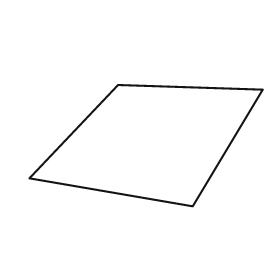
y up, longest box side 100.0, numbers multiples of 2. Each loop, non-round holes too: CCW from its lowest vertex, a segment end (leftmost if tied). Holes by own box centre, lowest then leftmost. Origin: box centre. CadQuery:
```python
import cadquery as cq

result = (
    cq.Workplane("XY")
    .moveTo(20.0, -26.0)
    .lineTo(50.0, 24.0)
    .lineTo(-12.0, 26.0)
    .lineTo(-50.0, -14.0)
    .close()
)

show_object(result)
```